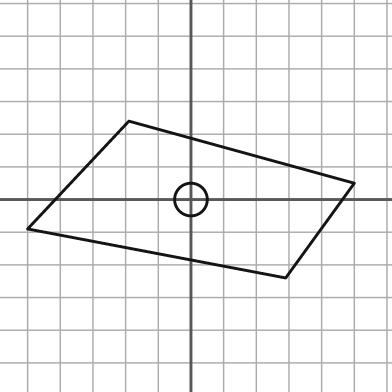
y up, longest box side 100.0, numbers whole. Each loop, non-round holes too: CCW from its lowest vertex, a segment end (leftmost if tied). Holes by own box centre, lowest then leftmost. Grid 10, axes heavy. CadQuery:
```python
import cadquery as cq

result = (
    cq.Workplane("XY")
    .moveTo(29.0, -24.0)
    .lineTo(50.0, 5.0)
    .lineTo(-19.0, 24.0)
    .lineTo(-50.0, -9.0)
    .close()
    .moveTo(0.0, 0.0)
    .circle(5.0)
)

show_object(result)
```